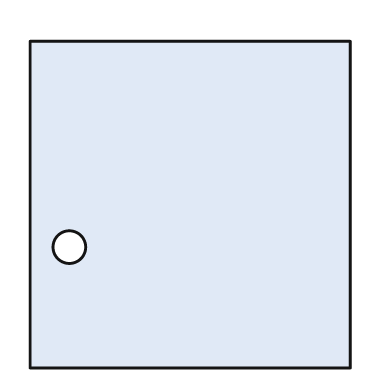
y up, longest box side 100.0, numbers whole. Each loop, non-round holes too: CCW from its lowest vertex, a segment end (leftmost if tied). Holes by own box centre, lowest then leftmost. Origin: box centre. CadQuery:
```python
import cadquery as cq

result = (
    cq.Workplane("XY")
    .moveTo(-49.0, -50.0)
    .lineTo(49.0, -50.0)
    .lineTo(49.0, 50.0)
    .lineTo(-49.0, 50.0)
    .close()
    .moveTo(-37.0, -13.0)
    .circle(5.0)
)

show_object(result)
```